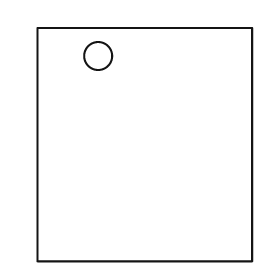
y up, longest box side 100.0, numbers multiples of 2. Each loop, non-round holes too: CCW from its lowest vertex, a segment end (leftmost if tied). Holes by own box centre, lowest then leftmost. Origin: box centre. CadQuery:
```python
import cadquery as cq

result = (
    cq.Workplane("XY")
    .moveTo(-46.0, -50.0)
    .lineTo(46.0, -50.0)
    .lineTo(46.0, 50.0)
    .lineTo(-46.0, 50.0)
    .close()
    .moveTo(-20.0, 38.0)
    .circle(6.0)
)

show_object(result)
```